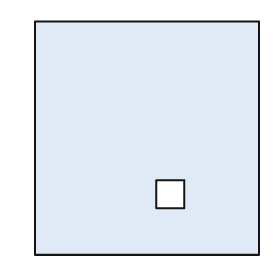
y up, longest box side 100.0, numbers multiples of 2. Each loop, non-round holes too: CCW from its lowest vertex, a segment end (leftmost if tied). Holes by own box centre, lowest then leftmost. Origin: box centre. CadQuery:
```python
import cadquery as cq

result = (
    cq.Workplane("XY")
    .moveTo(-48.0, -50.0)
    .lineTo(48.0, -50.0)
    .lineTo(48.0, 50.0)
    .lineTo(-48.0, 50.0)
    .close()
    .moveTo(4.0, -30.0)
    .lineTo(16.0, -30.0)
    .lineTo(16.0, -18.0)
    .lineTo(4.0, -18.0)
    .close()
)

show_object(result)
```